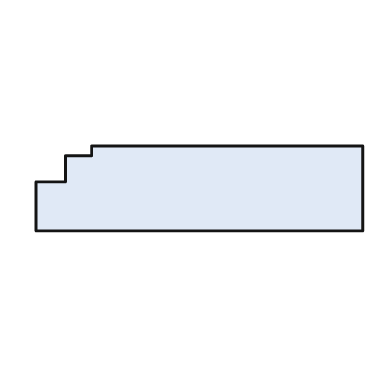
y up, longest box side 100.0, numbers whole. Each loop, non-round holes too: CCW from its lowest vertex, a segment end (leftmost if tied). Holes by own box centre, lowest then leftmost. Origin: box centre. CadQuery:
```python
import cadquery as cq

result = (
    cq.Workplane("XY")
    .moveTo(-50.0, -13.0)
    .lineTo(50.0, -13.0)
    .lineTo(50.0, 13.0)
    .lineTo(-33.0, 13.0)
    .lineTo(-33.0, 10.0)
    .lineTo(-41.0, 10.0)
    .lineTo(-41.0, 2.0)
    .lineTo(-50.0, 2.0)
    .close()
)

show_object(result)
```